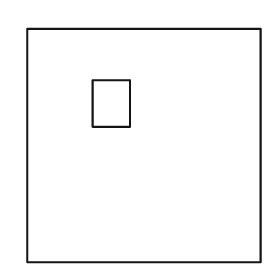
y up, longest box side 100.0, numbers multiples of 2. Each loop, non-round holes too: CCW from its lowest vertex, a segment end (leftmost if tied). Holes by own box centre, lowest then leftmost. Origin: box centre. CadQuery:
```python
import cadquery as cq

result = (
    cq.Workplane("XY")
    .moveTo(-50.0, -50.0)
    .lineTo(50.0, -50.0)
    .lineTo(50.0, 50.0)
    .lineTo(-50.0, 50.0)
    .close()
    .moveTo(-22.0, 8.0)
    .lineTo(-6.0, 8.0)
    .lineTo(-6.0, 28.0)
    .lineTo(-22.0, 28.0)
    .close()
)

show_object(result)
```